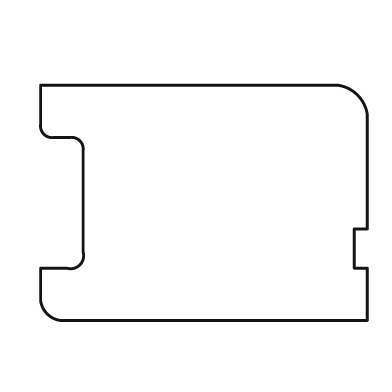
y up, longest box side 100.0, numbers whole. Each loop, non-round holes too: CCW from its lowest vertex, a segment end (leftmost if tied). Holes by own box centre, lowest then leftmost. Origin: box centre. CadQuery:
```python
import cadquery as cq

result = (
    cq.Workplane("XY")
    .moveTo(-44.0, -36.0)
    .lineTo(50.0, -36.0)
    .lineTo(50.0, -20.0)
    .lineTo(46.0, -20.0)
    .lineTo(46.0, -8.0)
    .lineTo(50.0, -8.0)
    .lineTo(50.0, 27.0)
    .threePointArc((47.0, 33.0), (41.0, 36.0))
    .lineTo(-50.0, 36.0)
    .lineTo(-50.0, 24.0)
    .threePointArc((-49.0, 21.0), (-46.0, 20.0))
    .lineTo(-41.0, 20.0)
    .threePointArc((-38.0, 19.0), (-37.0, 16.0))
    .lineTo(-37.0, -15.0)
    .threePointArc((-38.0, -19.0), (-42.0, -20.0))
    .lineTo(-50.0, -20.0)
    .lineTo(-50.0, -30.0)
    .threePointArc((-48.0, -34.0), (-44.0, -36.0))
    .close()
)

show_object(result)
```